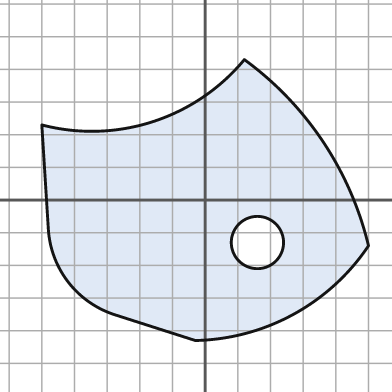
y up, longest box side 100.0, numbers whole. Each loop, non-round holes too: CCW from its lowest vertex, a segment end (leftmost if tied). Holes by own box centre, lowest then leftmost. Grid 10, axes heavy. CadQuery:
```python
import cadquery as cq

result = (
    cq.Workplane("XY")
    .moveTo(-3.0, -43.0)
    .threePointArc((27.0, -35.0), (50.0, -14.0))
    .threePointArc((36.0, 18.0), (12.0, 43.0))
    .threePointArc((-16.0, 24.0), (-50.0, 23.0))
    .lineTo(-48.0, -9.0)
    .threePointArc((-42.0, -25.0), (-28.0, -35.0))
    .close()
    .moveTo(16.0, -13.0)
    .circle(8.0)
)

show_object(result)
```